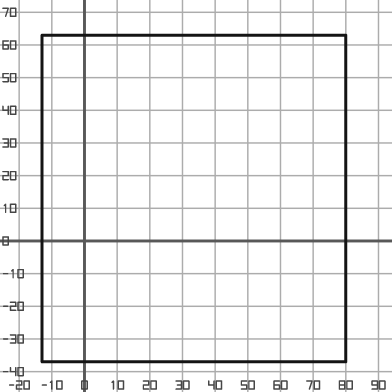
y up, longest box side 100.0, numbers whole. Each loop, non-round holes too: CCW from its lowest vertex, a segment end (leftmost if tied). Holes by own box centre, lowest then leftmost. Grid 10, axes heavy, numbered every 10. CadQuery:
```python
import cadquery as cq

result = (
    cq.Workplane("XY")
    .moveTo(-13.0, -37.0)
    .lineTo(80.0, -37.0)
    .lineTo(80.0, 63.0)
    .lineTo(-13.0, 63.0)
    .close()
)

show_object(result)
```